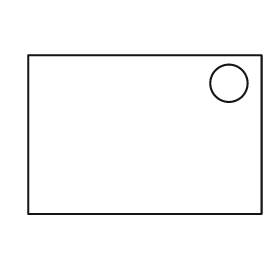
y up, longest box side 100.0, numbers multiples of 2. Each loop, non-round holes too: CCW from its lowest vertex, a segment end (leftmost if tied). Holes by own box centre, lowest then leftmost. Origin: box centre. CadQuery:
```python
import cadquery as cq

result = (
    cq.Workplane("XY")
    .moveTo(-50.0, -34.0)
    .lineTo(50.0, -34.0)
    .lineTo(50.0, 34.0)
    .lineTo(-50.0, 34.0)
    .close()
    .moveTo(36.0, 22.0)
    .circle(8.0)
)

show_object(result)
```